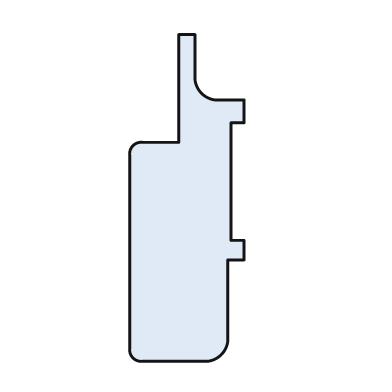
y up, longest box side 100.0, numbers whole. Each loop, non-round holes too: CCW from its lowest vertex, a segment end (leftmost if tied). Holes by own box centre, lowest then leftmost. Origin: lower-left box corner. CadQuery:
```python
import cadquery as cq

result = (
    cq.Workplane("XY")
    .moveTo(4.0, 0.0)
    .lineTo(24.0, 0.0)
    .threePointArc((28.0, 2.0), (30.0, 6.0))
    .lineTo(30.0, 31.0)
    .lineTo(35.0, 31.0)
    .lineTo(35.0, 37.0)
    .lineTo(31.0, 37.0)
    .lineTo(31.0, 73.0)
    .lineTo(35.0, 73.0)
    .lineTo(35.0, 80.0)
    .lineTo(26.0, 80.0)
    .threePointArc((22.0, 82.0), (20.0, 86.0))
    .lineTo(20.0, 100.0)
    .lineTo(15.0, 100.0)
    .lineTo(15.0, 67.0)
    .lineTo(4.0, 67.0)
    .threePointArc((1.0, 66.0), (0.0, 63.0))
    .lineTo(0.0, 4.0)
    .threePointArc((1.0, 1.0), (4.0, 0.0))
    .close()
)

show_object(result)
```